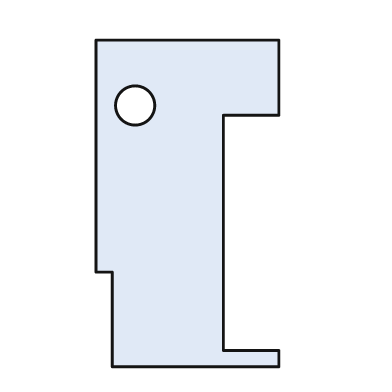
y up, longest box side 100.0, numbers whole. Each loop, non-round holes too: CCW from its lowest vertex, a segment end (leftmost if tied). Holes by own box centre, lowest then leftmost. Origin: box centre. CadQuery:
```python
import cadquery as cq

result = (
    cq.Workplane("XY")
    .moveTo(-23.0, -50.0)
    .lineTo(28.0, -50.0)
    .lineTo(28.0, -45.0)
    .lineTo(11.0, -45.0)
    .lineTo(11.0, 27.0)
    .lineTo(28.0, 27.0)
    .lineTo(28.0, 50.0)
    .lineTo(-28.0, 50.0)
    .lineTo(-28.0, -21.0)
    .lineTo(-23.0, -21.0)
    .close()
    .moveTo(-16.0, 30.0)
    .circle(6.0)
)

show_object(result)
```